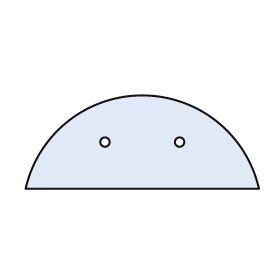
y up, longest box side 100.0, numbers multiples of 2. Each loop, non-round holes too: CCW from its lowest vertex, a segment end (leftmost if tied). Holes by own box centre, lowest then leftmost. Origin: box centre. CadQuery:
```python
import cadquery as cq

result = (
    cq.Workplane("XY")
    .moveTo(-50.0, -20.0)
    .lineTo(50.0, -20.0)
    .threePointArc((0.0, 20.0), (-50.0, -20.0))
    .close()
    .moveTo(-16.0, 0.0)
    .circle(2.0)
    .moveTo(16.0, 0.0)
    .circle(2.0)
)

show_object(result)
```